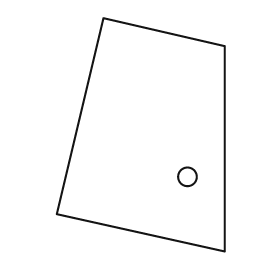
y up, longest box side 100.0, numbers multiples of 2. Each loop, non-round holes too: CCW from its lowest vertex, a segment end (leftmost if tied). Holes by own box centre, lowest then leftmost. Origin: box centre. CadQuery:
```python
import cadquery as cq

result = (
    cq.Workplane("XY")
    .moveTo(36.0, -50.0)
    .lineTo(36.0, 38.0)
    .lineTo(-16.0, 50.0)
    .lineTo(-36.0, -34.0)
    .close()
    .moveTo(20.0, -18.0)
    .circle(4.0)
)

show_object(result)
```